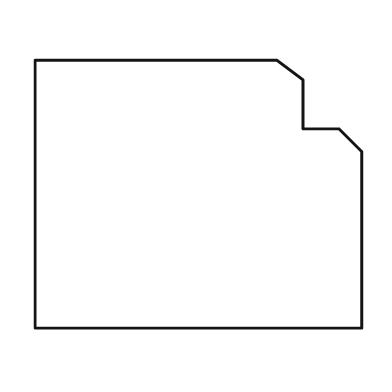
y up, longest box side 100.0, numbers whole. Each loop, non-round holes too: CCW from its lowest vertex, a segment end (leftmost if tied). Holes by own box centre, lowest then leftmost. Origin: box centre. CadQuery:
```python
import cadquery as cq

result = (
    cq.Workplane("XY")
    .moveTo(-50.0, -41.0)
    .lineTo(50.0, -41.0)
    .lineTo(50.0, 13.0)
    .lineTo(43.0, 20.0)
    .lineTo(32.0, 20.0)
    .lineTo(32.0, 35.0)
    .lineTo(24.0, 41.0)
    .lineTo(-50.0, 41.0)
    .close()
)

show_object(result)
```